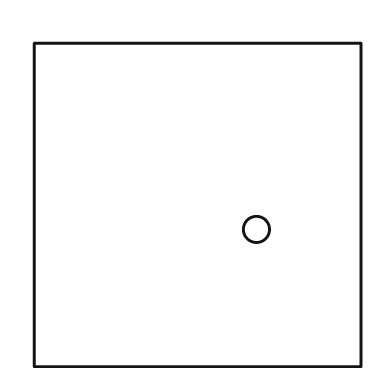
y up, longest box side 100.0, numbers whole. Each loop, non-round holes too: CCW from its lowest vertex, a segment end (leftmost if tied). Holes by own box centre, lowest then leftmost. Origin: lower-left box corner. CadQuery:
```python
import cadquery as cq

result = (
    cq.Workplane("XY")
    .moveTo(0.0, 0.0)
    .lineTo(100.0, 0.0)
    .lineTo(100.0, 99.0)
    .lineTo(0.0, 99.0)
    .close()
    .moveTo(68.0, 42.0)
    .circle(4.0)
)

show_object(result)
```